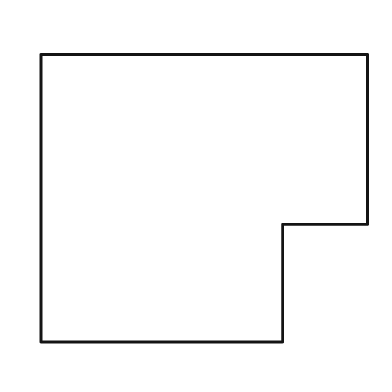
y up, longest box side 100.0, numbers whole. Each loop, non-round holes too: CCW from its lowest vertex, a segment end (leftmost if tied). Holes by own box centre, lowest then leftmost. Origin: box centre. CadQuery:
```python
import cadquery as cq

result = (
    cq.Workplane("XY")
    .moveTo(-50.0, -44.0)
    .lineTo(24.0, -44.0)
    .lineTo(24.0, -8.0)
    .lineTo(50.0, -8.0)
    .lineTo(50.0, 44.0)
    .lineTo(-50.0, 44.0)
    .close()
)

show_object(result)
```